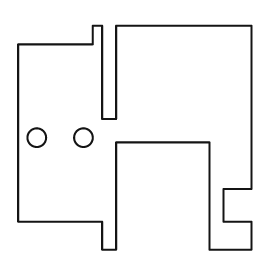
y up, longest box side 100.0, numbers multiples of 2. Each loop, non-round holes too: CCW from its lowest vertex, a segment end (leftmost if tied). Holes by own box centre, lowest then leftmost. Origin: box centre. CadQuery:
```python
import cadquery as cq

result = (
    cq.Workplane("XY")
    .moveTo(-14.0, -48.0)
    .lineTo(-8.0, -48.0)
    .lineTo(-8.0, -2.0)
    .lineTo(32.0, -2.0)
    .lineTo(32.0, -48.0)
    .lineTo(50.0, -48.0)
    .lineTo(50.0, -36.0)
    .lineTo(38.0, -36.0)
    .lineTo(38.0, -22.0)
    .lineTo(50.0, -22.0)
    .lineTo(50.0, 48.0)
    .lineTo(-8.0, 48.0)
    .lineTo(-8.0, 8.0)
    .lineTo(-14.0, 8.0)
    .lineTo(-14.0, 48.0)
    .lineTo(-18.0, 48.0)
    .lineTo(-18.0, 40.0)
    .lineTo(-50.0, 40.0)
    .lineTo(-50.0, -36.0)
    .lineTo(-14.0, -36.0)
    .close()
    .moveTo(-42.0, 0.0)
    .circle(4.0)
    .moveTo(-22.0, 0.0)
    .circle(4.0)
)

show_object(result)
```